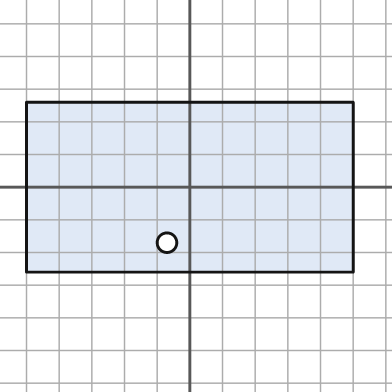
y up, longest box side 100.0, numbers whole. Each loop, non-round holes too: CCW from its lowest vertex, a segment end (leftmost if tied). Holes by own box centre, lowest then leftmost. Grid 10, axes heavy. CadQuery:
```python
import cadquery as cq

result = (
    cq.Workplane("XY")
    .moveTo(-50.0, -26.0)
    .lineTo(50.0, -26.0)
    .lineTo(50.0, 26.0)
    .lineTo(-50.0, 26.0)
    .close()
    .moveTo(-7.0, -17.0)
    .circle(3.0)
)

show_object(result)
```